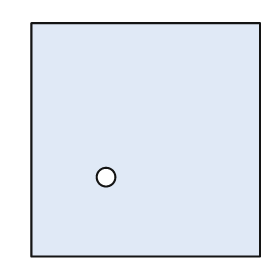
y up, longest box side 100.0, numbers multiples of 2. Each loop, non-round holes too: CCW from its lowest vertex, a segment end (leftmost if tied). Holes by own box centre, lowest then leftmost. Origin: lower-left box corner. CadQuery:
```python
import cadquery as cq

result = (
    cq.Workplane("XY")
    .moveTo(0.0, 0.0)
    .lineTo(98.0, 0.0)
    .lineTo(98.0, 100.0)
    .lineTo(0.0, 100.0)
    .close()
    .moveTo(32.0, 34.0)
    .circle(4.0)
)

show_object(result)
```